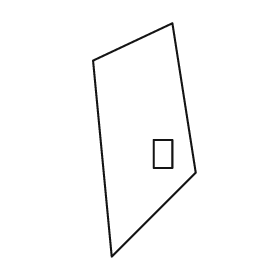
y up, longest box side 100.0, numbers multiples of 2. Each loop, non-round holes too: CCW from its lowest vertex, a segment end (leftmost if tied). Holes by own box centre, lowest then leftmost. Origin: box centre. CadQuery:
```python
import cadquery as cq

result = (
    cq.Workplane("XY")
    .moveTo(-14.0, -50.0)
    .lineTo(22.0, -14.0)
    .lineTo(12.0, 50.0)
    .lineTo(-22.0, 34.0)
    .close()
    .moveTo(4.0, -12.0)
    .lineTo(12.0, -12.0)
    .lineTo(12.0, 0.0)
    .lineTo(4.0, 0.0)
    .close()
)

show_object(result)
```